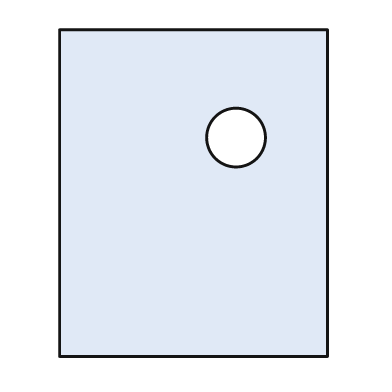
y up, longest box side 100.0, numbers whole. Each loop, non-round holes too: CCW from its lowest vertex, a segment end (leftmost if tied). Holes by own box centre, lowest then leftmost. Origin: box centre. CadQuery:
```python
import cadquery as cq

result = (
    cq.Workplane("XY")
    .moveTo(-41.0, -50.0)
    .lineTo(41.0, -50.0)
    .lineTo(41.0, 50.0)
    .lineTo(-41.0, 50.0)
    .close()
    .moveTo(13.0, 17.0)
    .circle(9.0)
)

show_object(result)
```